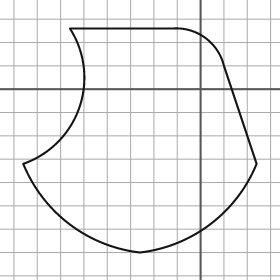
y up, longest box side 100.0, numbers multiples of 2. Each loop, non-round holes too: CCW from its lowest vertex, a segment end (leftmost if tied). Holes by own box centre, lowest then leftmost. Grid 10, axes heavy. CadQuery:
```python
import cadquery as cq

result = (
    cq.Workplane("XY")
    .moveTo(-26.0, -70.0)
    .threePointArc((4.0, -58.0), (24.0, -32.0))
    .lineTo(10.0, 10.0)
    .threePointArc((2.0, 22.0), (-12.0, 26.0))
    .lineTo(-56.0, 26.0)
    .threePointArc((-52.0, -8.0), (-76.0, -32.0))
    .threePointArc((-56.0, -58.0), (-26.0, -70.0))
    .close()
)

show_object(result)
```